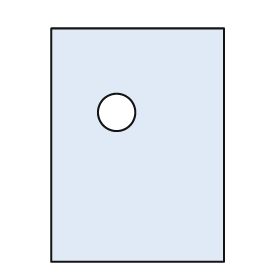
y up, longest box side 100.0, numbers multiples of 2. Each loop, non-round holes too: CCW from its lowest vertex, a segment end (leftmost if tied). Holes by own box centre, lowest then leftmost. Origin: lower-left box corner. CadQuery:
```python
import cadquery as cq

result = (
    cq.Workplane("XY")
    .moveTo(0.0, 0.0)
    .lineTo(74.0, 0.0)
    .lineTo(74.0, 100.0)
    .lineTo(0.0, 100.0)
    .close()
    .moveTo(28.0, 64.0)
    .circle(8.0)
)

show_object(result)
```